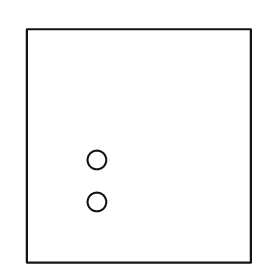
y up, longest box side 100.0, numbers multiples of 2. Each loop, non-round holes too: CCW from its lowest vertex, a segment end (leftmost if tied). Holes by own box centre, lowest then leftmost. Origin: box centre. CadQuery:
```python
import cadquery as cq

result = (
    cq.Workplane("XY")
    .moveTo(-48.0, -50.0)
    .lineTo(48.0, -50.0)
    .lineTo(48.0, 50.0)
    .lineTo(-48.0, 50.0)
    .close()
    .moveTo(-18.0, -24.0)
    .circle(4.0)
    .moveTo(-18.0, -6.0)
    .circle(4.0)
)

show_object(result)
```